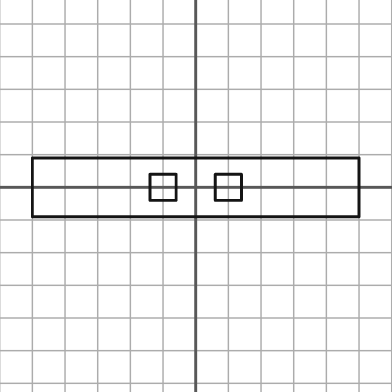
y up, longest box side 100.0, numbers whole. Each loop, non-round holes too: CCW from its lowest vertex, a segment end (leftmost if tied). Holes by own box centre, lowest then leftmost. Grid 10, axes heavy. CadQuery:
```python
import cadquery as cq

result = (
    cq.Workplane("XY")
    .moveTo(-50.0, -9.0)
    .lineTo(50.0, -9.0)
    .lineTo(50.0, 9.0)
    .lineTo(-50.0, 9.0)
    .close()
    .moveTo(-14.0, -4.0)
    .lineTo(-6.0, -4.0)
    .lineTo(-6.0, 4.0)
    .lineTo(-14.0, 4.0)
    .close()
    .moveTo(6.0, -4.0)
    .lineTo(14.0, -4.0)
    .lineTo(14.0, 4.0)
    .lineTo(6.0, 4.0)
    .close()
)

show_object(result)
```